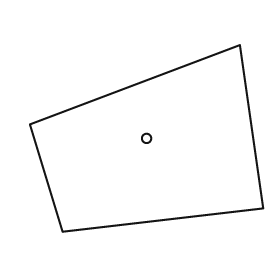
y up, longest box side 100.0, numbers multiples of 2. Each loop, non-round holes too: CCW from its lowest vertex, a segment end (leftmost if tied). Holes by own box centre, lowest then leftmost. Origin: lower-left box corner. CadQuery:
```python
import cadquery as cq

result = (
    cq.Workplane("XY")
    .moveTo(14.0, 0.0)
    .lineTo(100.0, 10.0)
    .lineTo(90.0, 80.0)
    .lineTo(0.0, 46.0)
    .close()
    .moveTo(50.0, 40.0)
    .circle(2.0)
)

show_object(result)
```